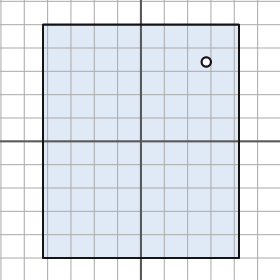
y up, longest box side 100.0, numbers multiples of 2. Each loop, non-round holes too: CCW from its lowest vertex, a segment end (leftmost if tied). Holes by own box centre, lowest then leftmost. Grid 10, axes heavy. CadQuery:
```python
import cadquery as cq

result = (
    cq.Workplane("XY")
    .moveTo(-42.0, -50.0)
    .lineTo(42.0, -50.0)
    .lineTo(42.0, 50.0)
    .lineTo(-42.0, 50.0)
    .close()
    .moveTo(28.0, 34.0)
    .circle(2.0)
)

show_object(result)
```